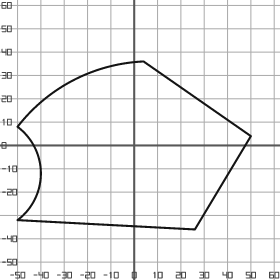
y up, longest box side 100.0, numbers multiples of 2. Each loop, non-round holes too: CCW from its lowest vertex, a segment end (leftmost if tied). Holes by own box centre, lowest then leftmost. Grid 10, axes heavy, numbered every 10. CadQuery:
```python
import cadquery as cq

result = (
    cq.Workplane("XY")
    .moveTo(26.0, -36.0)
    .lineTo(50.0, 4.0)
    .lineTo(4.0, 36.0)
    .threePointArc((-26.0, 28.0), (-50.0, 8.0))
    .threePointArc((-40.0, -12.0), (-50.0, -32.0))
    .close()
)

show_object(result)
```